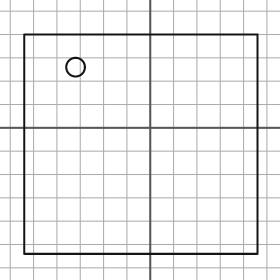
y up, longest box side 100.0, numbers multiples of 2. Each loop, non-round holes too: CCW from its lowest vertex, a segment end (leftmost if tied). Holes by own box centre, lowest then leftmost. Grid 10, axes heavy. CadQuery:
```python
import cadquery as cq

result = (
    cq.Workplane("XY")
    .moveTo(-54.0, -54.0)
    .lineTo(46.0, -54.0)
    .lineTo(46.0, 40.0)
    .lineTo(-54.0, 40.0)
    .close()
    .moveTo(-32.0, 26.0)
    .circle(4.0)
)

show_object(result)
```